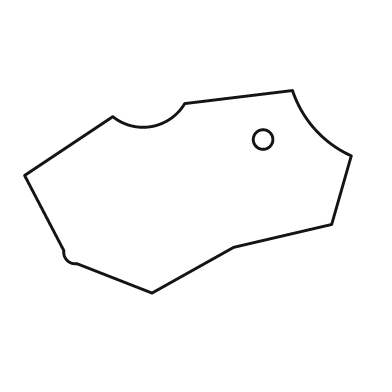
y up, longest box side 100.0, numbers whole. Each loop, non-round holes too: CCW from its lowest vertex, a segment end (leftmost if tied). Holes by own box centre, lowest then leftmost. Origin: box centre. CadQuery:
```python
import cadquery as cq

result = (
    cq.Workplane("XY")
    .moveTo(-11.0, -31.0)
    .lineTo(14.0, -17.0)
    .lineTo(44.0, -10.0)
    .lineTo(50.0, 11.0)
    .threePointArc((39.0, 19.0), (32.0, 31.0))
    .lineTo(-1.0, 27.0)
    .threePointArc((-11.0, 20.0), (-23.0, 23.0))
    .lineTo(-50.0, 5.0)
    .lineTo(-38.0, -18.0)
    .threePointArc((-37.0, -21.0), (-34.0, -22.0))
    .close()
    .moveTo(23.0, 16.0)
    .circle(3.0)
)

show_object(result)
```